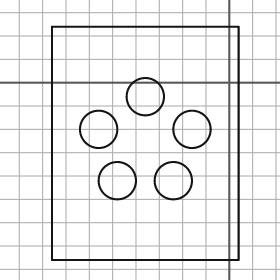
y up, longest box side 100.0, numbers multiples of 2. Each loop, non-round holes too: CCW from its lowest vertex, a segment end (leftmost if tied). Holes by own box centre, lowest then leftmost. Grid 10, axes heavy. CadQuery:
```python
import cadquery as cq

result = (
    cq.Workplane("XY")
    .moveTo(-76.0, -76.0)
    .lineTo(4.0, -76.0)
    .lineTo(4.0, 24.0)
    .lineTo(-76.0, 24.0)
    .close()
    .moveTo(-48.0, -42.0)
    .circle(8.0)
    .moveTo(-24.0, -42.0)
    .circle(8.0)
    .moveTo(-56.0, -20.0)
    .circle(8.0)
    .moveTo(-16.0, -20.0)
    .circle(8.0)
    .moveTo(-36.0, -6.0)
    .circle(8.0)
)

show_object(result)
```